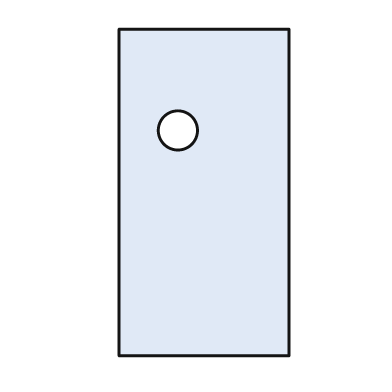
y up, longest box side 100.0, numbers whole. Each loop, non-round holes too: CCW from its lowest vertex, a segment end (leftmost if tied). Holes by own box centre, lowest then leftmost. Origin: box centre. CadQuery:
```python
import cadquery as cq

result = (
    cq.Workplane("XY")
    .moveTo(-26.0, -50.0)
    .lineTo(26.0, -50.0)
    .lineTo(26.0, 50.0)
    .lineTo(-26.0, 50.0)
    .close()
    .moveTo(-8.0, 19.0)
    .circle(6.0)
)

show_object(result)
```